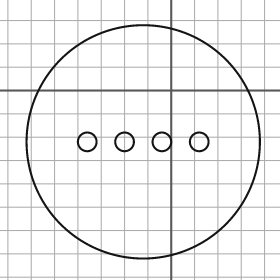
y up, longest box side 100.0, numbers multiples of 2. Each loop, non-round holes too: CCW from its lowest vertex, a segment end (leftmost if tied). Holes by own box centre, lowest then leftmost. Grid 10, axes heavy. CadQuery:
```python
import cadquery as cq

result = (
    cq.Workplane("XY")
    .moveTo(-12.0, -22.0)
    .circle(50.0)
    .moveTo(-36.0, -22.0)
    .circle(4.0)
    .moveTo(-20.0, -22.0)
    .circle(4.0)
    .moveTo(-4.0, -22.0)
    .circle(4.0)
    .moveTo(12.0, -22.0)
    .circle(4.0)
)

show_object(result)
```